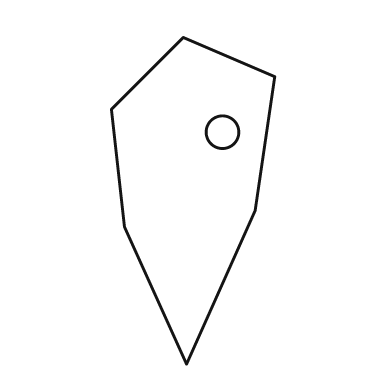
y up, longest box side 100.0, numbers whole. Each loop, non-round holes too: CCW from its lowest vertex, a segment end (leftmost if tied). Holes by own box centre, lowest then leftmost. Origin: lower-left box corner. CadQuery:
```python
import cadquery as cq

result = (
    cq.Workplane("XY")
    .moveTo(23.0, 0.0)
    .lineTo(44.0, 47.0)
    .lineTo(50.0, 88.0)
    .lineTo(22.0, 100.0)
    .lineTo(0.0, 78.0)
    .lineTo(4.0, 42.0)
    .close()
    .moveTo(34.0, 71.0)
    .circle(5.0)
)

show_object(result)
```